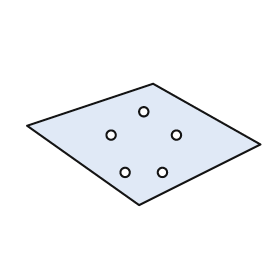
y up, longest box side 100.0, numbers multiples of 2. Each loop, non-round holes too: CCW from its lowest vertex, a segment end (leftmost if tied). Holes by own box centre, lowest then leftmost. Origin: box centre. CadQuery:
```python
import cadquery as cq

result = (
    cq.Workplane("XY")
    .moveTo(-2.0, -26.0)
    .lineTo(50.0, 0.0)
    .lineTo(4.0, 26.0)
    .lineTo(-50.0, 8.0)
    .close()
    .moveTo(-8.0, -12.0)
    .circle(2.0)
    .moveTo(8.0, -12.0)
    .circle(2.0)
    .moveTo(-14.0, 4.0)
    .circle(2.0)
    .moveTo(14.0, 4.0)
    .circle(2.0)
    .moveTo(0.0, 14.0)
    .circle(2.0)
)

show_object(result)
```